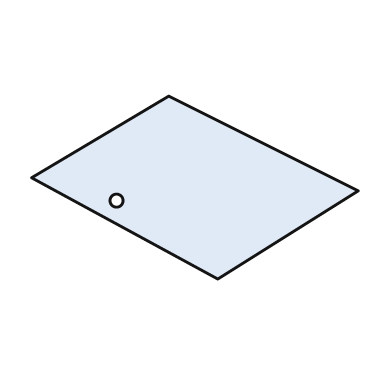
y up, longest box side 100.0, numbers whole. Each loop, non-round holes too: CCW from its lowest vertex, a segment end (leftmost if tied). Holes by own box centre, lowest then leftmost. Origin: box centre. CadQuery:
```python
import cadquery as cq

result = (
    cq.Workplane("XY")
    .moveTo(7.0, -28.0)
    .lineTo(50.0, -1.0)
    .lineTo(-8.0, 28.0)
    .lineTo(-50.0, 3.0)
    .close()
    .moveTo(-24.0, -4.0)
    .circle(2.0)
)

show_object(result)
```